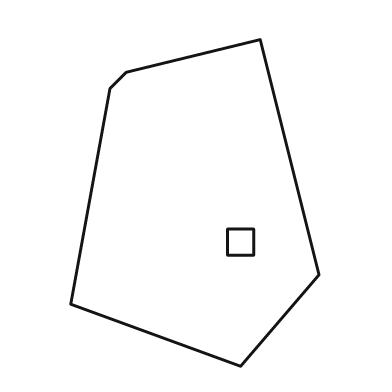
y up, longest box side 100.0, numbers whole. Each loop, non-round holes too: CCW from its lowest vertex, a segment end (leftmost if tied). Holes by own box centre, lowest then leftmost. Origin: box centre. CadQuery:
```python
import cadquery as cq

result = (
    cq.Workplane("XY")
    .moveTo(14.0, -50.0)
    .lineTo(38.0, -22.0)
    .lineTo(20.0, 50.0)
    .lineTo(-21.0, 40.0)
    .lineTo(-26.0, 35.0)
    .lineTo(-38.0, -31.0)
    .close()
    .moveTo(10.0, -16.0)
    .lineTo(18.0, -16.0)
    .lineTo(18.0, -8.0)
    .lineTo(10.0, -8.0)
    .close()
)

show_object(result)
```